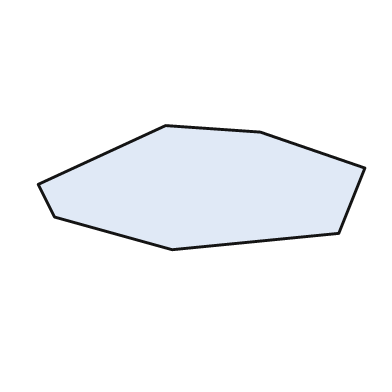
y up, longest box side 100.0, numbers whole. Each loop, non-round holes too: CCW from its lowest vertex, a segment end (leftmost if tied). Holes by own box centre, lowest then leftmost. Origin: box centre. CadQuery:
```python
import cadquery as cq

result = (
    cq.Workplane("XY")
    .moveTo(-9.0, -19.0)
    .lineTo(42.0, -14.0)
    .lineTo(50.0, 6.0)
    .lineTo(18.0, 17.0)
    .lineTo(-11.0, 19.0)
    .lineTo(-50.0, 1.0)
    .lineTo(-45.0, -9.0)
    .close()
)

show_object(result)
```